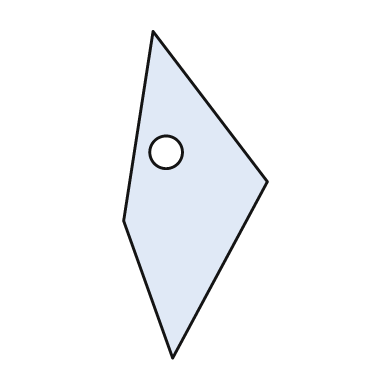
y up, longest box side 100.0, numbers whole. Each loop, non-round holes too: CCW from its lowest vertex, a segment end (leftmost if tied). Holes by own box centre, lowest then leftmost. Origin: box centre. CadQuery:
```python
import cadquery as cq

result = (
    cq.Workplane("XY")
    .moveTo(-7.0, -50.0)
    .lineTo(22.0, 4.0)
    .lineTo(-13.0, 50.0)
    .lineTo(-22.0, -8.0)
    .close()
    .moveTo(-9.0, 13.0)
    .circle(5.0)
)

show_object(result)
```